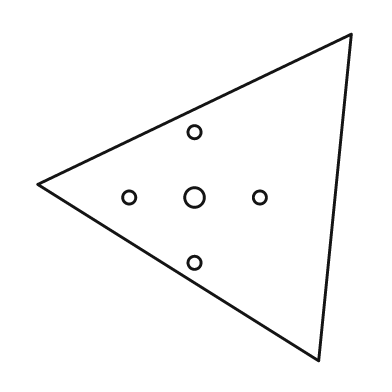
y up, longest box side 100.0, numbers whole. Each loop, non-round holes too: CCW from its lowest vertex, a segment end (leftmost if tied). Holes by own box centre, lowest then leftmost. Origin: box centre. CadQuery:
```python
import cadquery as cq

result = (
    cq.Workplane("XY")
    .moveTo(38.0, -50.0)
    .lineTo(48.0, 50.0)
    .lineTo(-48.0, 4.0)
    .close()
    .moveTo(0.0, -20.0)
    .circle(2.0)
    .moveTo(-20.0, 0.0)
    .circle(2.0)
    .moveTo(0.0, 0.0)
    .circle(3.0)
    .moveTo(20.0, 0.0)
    .circle(2.0)
    .moveTo(0.0, 20.0)
    .circle(2.0)
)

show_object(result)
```